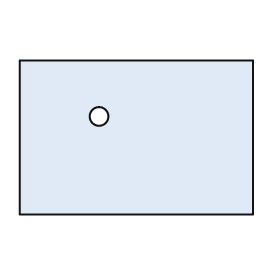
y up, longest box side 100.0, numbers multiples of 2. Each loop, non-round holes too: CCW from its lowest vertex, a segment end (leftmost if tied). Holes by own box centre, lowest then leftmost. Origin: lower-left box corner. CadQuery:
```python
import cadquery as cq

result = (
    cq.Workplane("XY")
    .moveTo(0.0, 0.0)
    .lineTo(100.0, 0.0)
    .lineTo(100.0, 66.0)
    .lineTo(0.0, 66.0)
    .close()
    .moveTo(34.0, 42.0)
    .circle(4.0)
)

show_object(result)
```